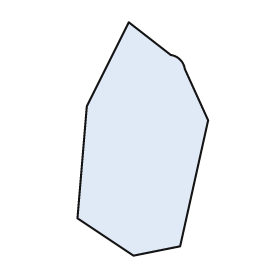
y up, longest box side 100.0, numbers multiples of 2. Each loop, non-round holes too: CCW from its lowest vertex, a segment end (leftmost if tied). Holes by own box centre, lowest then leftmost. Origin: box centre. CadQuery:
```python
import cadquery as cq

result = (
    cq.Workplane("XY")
    .moveTo(-4.0, -50.0)
    .lineTo(16.0, -46.0)
    .lineTo(28.0, 8.0)
    .lineTo(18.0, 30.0)
    .threePointArc((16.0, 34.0), (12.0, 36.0))
    .lineTo(-6.0, 50.0)
    .lineTo(-24.0, 14.0)
    .lineTo(-28.0, -34.0)
    .close()
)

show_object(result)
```